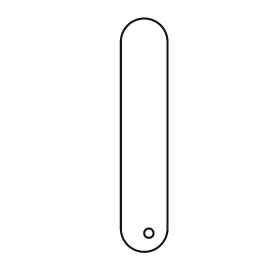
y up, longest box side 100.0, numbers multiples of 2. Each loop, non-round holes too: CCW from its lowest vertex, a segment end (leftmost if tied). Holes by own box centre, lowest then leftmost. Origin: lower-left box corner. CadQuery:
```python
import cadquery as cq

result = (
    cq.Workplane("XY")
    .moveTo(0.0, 10.0)
    .threePointArc((10.0, 0.0), (20.0, 10.0))
    .lineTo(20.0, 90.0)
    .threePointArc((10.0, 100.0), (0.0, 90.0))
    .close()
    .moveTo(12.0, 8.0)
    .circle(2.0)
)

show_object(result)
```